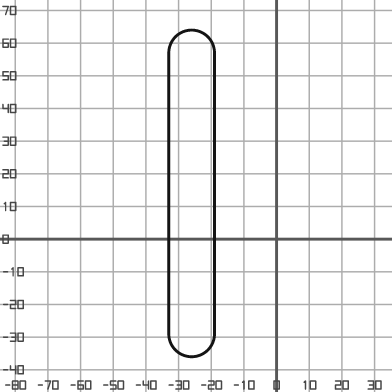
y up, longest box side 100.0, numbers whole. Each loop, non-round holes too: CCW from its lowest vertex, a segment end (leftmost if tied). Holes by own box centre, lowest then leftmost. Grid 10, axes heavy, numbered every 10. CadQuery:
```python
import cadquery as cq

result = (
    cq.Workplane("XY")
    .moveTo(-33.0, -29.0)
    .threePointArc((-26.0, -36.0), (-19.0, -29.0))
    .lineTo(-19.0, 57.0)
    .threePointArc((-26.0, 64.0), (-33.0, 57.0))
    .close()
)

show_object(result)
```